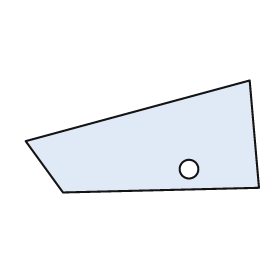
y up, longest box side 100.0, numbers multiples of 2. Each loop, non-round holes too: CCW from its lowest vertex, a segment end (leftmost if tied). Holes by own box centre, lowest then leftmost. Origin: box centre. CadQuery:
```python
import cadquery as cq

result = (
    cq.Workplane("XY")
    .moveTo(-34.0, -24.0)
    .lineTo(50.0, -22.0)
    .lineTo(46.0, 24.0)
    .lineTo(-50.0, -2.0)
    .close()
    .moveTo(20.0, -14.0)
    .circle(4.0)
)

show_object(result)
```